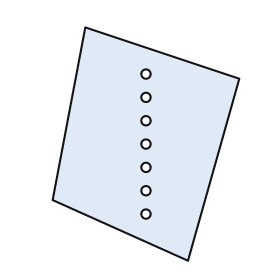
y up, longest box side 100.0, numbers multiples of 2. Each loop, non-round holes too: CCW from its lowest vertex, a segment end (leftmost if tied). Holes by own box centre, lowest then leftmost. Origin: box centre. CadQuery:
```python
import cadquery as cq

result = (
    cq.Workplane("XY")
    .moveTo(18.0, -50.0)
    .lineTo(40.0, 28.0)
    .lineTo(-26.0, 50.0)
    .lineTo(-40.0, -24.0)
    .close()
    .moveTo(0.0, -30.0)
    .circle(2.0)
    .moveTo(0.0, -20.0)
    .circle(2.0)
    .moveTo(0.0, -10.0)
    .circle(2.0)
    .moveTo(0.0, 0.0)
    .circle(2.0)
    .moveTo(0.0, 10.0)
    .circle(2.0)
    .moveTo(0.0, 20.0)
    .circle(2.0)
    .moveTo(0.0, 30.0)
    .circle(2.0)
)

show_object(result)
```